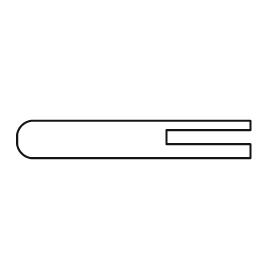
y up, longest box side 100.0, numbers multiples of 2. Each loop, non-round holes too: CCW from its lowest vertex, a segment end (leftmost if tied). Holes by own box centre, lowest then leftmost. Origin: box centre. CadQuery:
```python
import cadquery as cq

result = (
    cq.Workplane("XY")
    .moveTo(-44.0, -8.0)
    .lineTo(50.0, -8.0)
    .lineTo(50.0, -2.0)
    .lineTo(14.0, -2.0)
    .lineTo(14.0, 4.0)
    .lineTo(50.0, 4.0)
    .lineTo(50.0, 8.0)
    .lineTo(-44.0, 8.0)
    .threePointArc((-48.0, 6.0), (-50.0, 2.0))
    .lineTo(-50.0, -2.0)
    .threePointArc((-48.0, -6.0), (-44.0, -8.0))
    .close()
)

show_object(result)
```